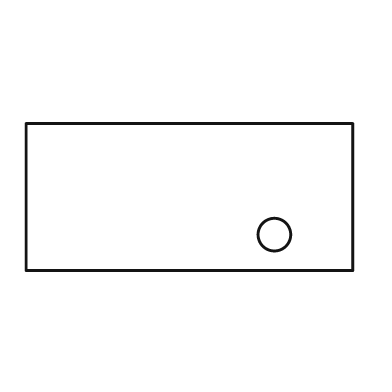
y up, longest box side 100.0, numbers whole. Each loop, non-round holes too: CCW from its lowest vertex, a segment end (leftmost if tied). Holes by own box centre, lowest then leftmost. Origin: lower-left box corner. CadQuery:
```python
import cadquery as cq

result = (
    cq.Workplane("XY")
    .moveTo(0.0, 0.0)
    .lineTo(100.0, 0.0)
    .lineTo(100.0, 45.0)
    .lineTo(0.0, 45.0)
    .close()
    .moveTo(76.0, 11.0)
    .circle(5.0)
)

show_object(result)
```